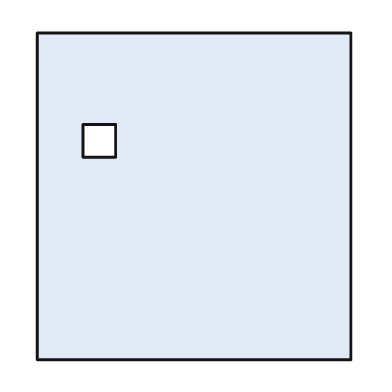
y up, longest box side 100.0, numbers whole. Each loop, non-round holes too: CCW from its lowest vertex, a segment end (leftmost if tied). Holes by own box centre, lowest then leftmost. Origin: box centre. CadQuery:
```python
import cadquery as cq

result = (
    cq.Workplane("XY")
    .moveTo(-48.0, -50.0)
    .lineTo(48.0, -50.0)
    .lineTo(48.0, 50.0)
    .lineTo(-48.0, 50.0)
    .close()
    .moveTo(-34.0, 12.0)
    .lineTo(-24.0, 12.0)
    .lineTo(-24.0, 22.0)
    .lineTo(-34.0, 22.0)
    .close()
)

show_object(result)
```